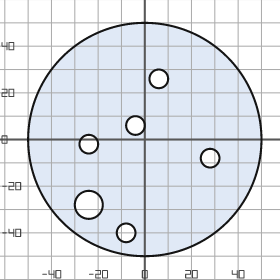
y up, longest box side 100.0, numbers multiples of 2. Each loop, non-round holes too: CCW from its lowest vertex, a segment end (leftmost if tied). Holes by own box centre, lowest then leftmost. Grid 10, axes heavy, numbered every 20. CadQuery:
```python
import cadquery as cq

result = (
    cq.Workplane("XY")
    .moveTo(0.0, 0.0)
    .circle(50.0)
    .moveTo(-8.0, -40.0)
    .circle(4.0)
    .moveTo(-24.0, -28.0)
    .circle(6.0)
    .moveTo(28.0, -8.0)
    .circle(4.0)
    .moveTo(-24.0, -2.0)
    .circle(4.0)
    .moveTo(-4.0, 6.0)
    .circle(4.0)
    .moveTo(6.0, 26.0)
    .circle(4.0)
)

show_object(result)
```